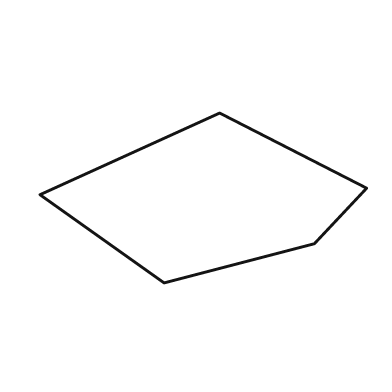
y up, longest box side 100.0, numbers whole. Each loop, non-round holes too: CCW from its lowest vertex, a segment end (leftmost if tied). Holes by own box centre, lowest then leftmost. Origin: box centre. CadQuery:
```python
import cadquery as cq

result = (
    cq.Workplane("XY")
    .moveTo(-12.0, -26.0)
    .lineTo(34.0, -14.0)
    .lineTo(50.0, 3.0)
    .lineTo(5.0, 26.0)
    .lineTo(-50.0, 1.0)
    .close()
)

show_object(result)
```